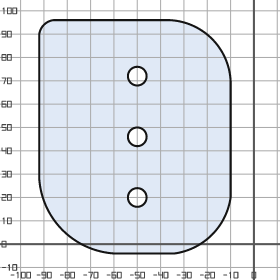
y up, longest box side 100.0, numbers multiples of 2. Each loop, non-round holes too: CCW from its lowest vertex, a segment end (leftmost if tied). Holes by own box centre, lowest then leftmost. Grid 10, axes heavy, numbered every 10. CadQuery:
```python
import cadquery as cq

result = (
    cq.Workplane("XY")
    .moveTo(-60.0, -4.0)
    .lineTo(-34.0, -4.0)
    .threePointArc((-18.0, 4.0), (-10.0, 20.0))
    .lineTo(-10.0, 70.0)
    .threePointArc((-18.0, 88.0), (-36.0, 96.0))
    .lineTo(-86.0, 96.0)
    .threePointArc((-90.0, 94.0), (-92.0, 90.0))
    .lineTo(-92.0, 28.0)
    .threePointArc((-82.0, 6.0), (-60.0, -4.0))
    .close()
    .moveTo(-50.0, 20.0)
    .circle(4.0)
    .moveTo(-50.0, 46.0)
    .circle(4.0)
    .moveTo(-50.0, 72.0)
    .circle(4.0)
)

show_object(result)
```